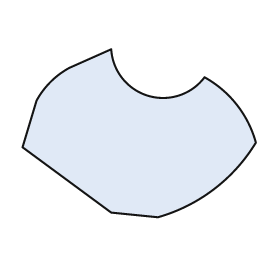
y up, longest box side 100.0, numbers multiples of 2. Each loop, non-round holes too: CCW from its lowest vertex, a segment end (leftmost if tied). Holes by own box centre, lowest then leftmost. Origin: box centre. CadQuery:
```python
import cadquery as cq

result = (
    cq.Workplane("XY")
    .moveTo(8.0, -36.0)
    .threePointArc((32.0, -24.0), (50.0, -4.0))
    .threePointArc((42.0, 12.0), (28.0, 24.0))
    .threePointArc((4.0, 16.0), (-12.0, 36.0))
    .lineTo(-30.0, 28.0)
    .threePointArc((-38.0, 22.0), (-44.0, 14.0))
    .lineTo(-50.0, -6.0)
    .lineTo(-12.0, -34.0)
    .close()
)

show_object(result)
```